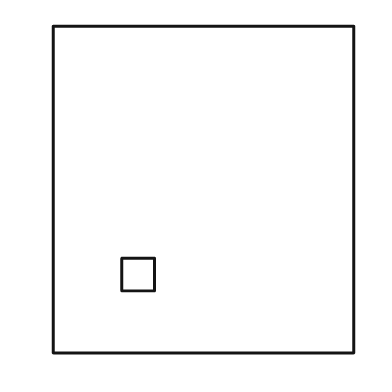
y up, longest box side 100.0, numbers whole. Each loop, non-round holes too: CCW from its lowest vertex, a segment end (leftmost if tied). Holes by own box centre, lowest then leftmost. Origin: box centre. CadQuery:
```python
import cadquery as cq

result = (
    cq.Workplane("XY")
    .moveTo(-46.0, -50.0)
    .lineTo(46.0, -50.0)
    .lineTo(46.0, 50.0)
    .lineTo(-46.0, 50.0)
    .close()
    .moveTo(-25.0, -31.0)
    .lineTo(-15.0, -31.0)
    .lineTo(-15.0, -21.0)
    .lineTo(-25.0, -21.0)
    .close()
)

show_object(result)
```